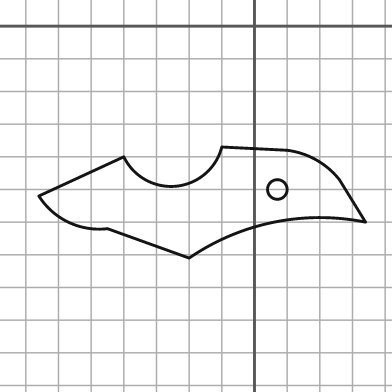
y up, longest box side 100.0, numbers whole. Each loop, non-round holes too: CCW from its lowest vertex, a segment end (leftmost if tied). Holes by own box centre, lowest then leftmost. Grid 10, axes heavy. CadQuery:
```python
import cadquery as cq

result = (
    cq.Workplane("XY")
    .moveTo(-20.0, -71.0)
    .threePointArc((6.0, -60.0), (34.0, -60.0))
    .lineTo(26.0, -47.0)
    .threePointArc((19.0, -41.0), (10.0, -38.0))
    .lineTo(-10.0, -37.0)
    .threePointArc((-24.0, -49.0), (-40.0, -40.0))
    .lineTo(-66.0, -52.0)
    .threePointArc((-57.0, -60.0), (-45.0, -62.0))
    .close()
    .moveTo(7.0, -50.0)
    .circle(3.0)
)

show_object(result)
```